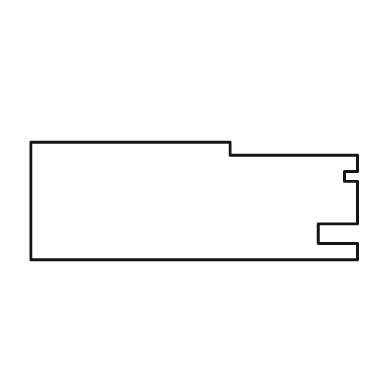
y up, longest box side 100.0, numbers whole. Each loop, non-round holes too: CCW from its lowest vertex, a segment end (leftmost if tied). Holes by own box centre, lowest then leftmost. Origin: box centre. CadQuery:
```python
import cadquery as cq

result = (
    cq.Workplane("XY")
    .moveTo(-50.0, -18.0)
    .lineTo(50.0, -18.0)
    .lineTo(50.0, -13.0)
    .lineTo(38.0, -13.0)
    .lineTo(38.0, -7.0)
    .lineTo(50.0, -7.0)
    .lineTo(50.0, 6.0)
    .lineTo(46.0, 6.0)
    .lineTo(46.0, 9.0)
    .lineTo(50.0, 9.0)
    .lineTo(50.0, 14.0)
    .lineTo(11.0, 14.0)
    .lineTo(11.0, 18.0)
    .lineTo(-50.0, 18.0)
    .close()
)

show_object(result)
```